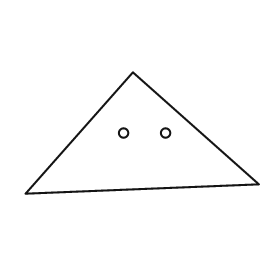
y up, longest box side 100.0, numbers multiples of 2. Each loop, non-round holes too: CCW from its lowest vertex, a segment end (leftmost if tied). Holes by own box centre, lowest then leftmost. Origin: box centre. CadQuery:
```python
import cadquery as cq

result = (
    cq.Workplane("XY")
    .moveTo(-50.0, -26.0)
    .lineTo(50.0, -22.0)
    .lineTo(-4.0, 26.0)
    .close()
    .moveTo(-8.0, 0.0)
    .circle(2.0)
    .moveTo(10.0, 0.0)
    .circle(2.0)
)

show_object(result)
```